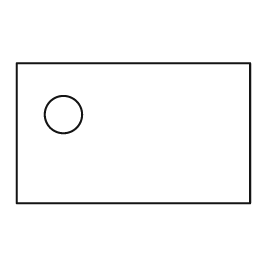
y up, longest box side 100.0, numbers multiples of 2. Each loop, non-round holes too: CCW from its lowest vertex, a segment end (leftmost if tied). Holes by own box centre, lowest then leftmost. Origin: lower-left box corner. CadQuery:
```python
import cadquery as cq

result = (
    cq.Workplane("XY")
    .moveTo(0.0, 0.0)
    .lineTo(100.0, 0.0)
    .lineTo(100.0, 60.0)
    .lineTo(0.0, 60.0)
    .close()
    .moveTo(20.0, 38.0)
    .circle(8.0)
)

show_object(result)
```